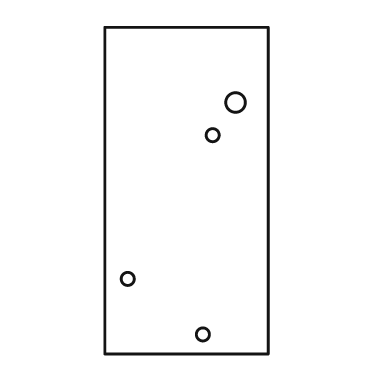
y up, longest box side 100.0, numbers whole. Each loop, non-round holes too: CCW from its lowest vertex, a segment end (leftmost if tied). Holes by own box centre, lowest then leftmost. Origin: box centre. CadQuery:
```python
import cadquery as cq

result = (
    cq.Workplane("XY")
    .moveTo(-25.0, -50.0)
    .lineTo(25.0, -50.0)
    .lineTo(25.0, 50.0)
    .lineTo(-25.0, 50.0)
    .close()
    .moveTo(5.0, -44.0)
    .circle(2.0)
    .moveTo(-18.0, -27.0)
    .circle(2.0)
    .moveTo(8.0, 17.0)
    .circle(2.0)
    .moveTo(15.0, 27.0)
    .circle(3.0)
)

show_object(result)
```